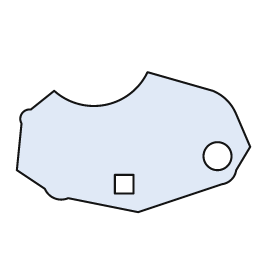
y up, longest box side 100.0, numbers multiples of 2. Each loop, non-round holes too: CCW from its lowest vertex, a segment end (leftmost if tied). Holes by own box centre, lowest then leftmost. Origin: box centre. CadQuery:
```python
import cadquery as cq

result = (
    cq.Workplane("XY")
    .moveTo(2.0, -30.0)
    .lineTo(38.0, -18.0)
    .threePointArc((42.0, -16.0), (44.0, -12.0))
    .lineTo(50.0, -2.0)
    .lineTo(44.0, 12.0)
    .threePointArc((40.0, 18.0), (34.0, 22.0))
    .lineTo(6.0, 30.0)
    .threePointArc((-12.0, 16.0), (-34.0, 22.0))
    .lineTo(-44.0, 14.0)
    .threePointArc((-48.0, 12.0), (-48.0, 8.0))
    .lineTo(-50.0, -12.0)
    .lineTo(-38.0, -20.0)
    .threePointArc((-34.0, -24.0), (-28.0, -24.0))
    .close()
    .moveTo(-8.0, -22.0)
    .lineTo(0.0, -22.0)
    .lineTo(0.0, -14.0)
    .lineTo(-8.0, -14.0)
    .close()
    .moveTo(36.0, -6.0)
    .circle(6.0)
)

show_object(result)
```